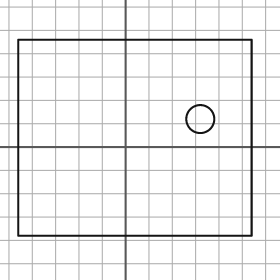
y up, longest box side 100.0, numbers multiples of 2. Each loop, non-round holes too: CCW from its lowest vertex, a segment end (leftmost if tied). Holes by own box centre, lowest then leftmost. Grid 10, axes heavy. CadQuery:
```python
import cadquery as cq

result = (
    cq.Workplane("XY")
    .moveTo(-46.0, -38.0)
    .lineTo(54.0, -38.0)
    .lineTo(54.0, 46.0)
    .lineTo(-46.0, 46.0)
    .close()
    .moveTo(32.0, 12.0)
    .circle(6.0)
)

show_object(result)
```